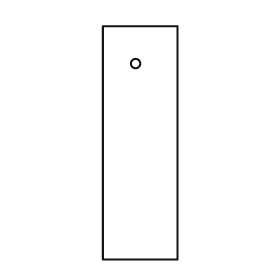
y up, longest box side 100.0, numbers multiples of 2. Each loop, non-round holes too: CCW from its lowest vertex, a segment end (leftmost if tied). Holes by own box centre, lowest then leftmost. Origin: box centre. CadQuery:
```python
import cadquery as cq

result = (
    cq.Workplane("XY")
    .moveTo(-16.0, -50.0)
    .lineTo(16.0, -50.0)
    .lineTo(16.0, 50.0)
    .lineTo(-16.0, 50.0)
    .close()
    .moveTo(-2.0, 34.0)
    .circle(2.0)
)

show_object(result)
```